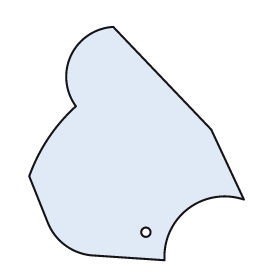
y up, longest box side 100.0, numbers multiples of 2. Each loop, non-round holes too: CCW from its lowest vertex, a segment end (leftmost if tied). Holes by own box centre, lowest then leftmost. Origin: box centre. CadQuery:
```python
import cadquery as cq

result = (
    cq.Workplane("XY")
    .moveTo(12.0, -50.0)
    .threePointArc((22.0, -28.0), (46.0, -24.0))
    .lineTo(32.0, 6.0)
    .lineTo(-10.0, 50.0)
    .threePointArc((-28.0, 38.0), (-26.0, 16.0))
    .threePointArc((-38.0, 2.0), (-46.0, -14.0))
    .lineTo(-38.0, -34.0)
    .threePointArc((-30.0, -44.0), (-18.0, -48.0))
    .close()
    .moveTo(4.0, -38.0)
    .circle(2.0)
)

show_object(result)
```